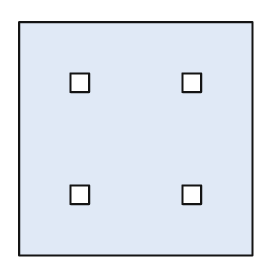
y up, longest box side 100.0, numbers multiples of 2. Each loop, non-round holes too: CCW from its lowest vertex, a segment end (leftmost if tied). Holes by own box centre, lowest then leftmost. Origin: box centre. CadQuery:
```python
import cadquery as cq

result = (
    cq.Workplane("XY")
    .moveTo(-50.0, -50.0)
    .lineTo(50.0, -50.0)
    .lineTo(50.0, 50.0)
    .lineTo(-50.0, 50.0)
    .close()
    .moveTo(-28.0, -28.0)
    .lineTo(-20.0, -28.0)
    .lineTo(-20.0, -20.0)
    .lineTo(-28.0, -20.0)
    .close()
    .moveTo(20.0, -28.0)
    .lineTo(28.0, -28.0)
    .lineTo(28.0, -20.0)
    .lineTo(20.0, -20.0)
    .close()
    .moveTo(-28.0, 20.0)
    .lineTo(-20.0, 20.0)
    .lineTo(-20.0, 28.0)
    .lineTo(-28.0, 28.0)
    .close()
    .moveTo(20.0, 20.0)
    .lineTo(28.0, 20.0)
    .lineTo(28.0, 28.0)
    .lineTo(20.0, 28.0)
    .close()
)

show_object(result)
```